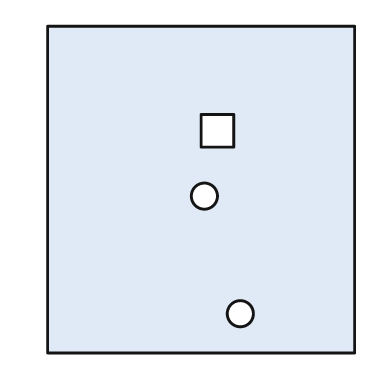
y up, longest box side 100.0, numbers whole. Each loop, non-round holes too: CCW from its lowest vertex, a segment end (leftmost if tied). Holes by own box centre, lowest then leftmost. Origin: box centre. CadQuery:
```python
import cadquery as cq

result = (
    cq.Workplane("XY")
    .moveTo(-47.0, -50.0)
    .lineTo(47.0, -50.0)
    .lineTo(47.0, 50.0)
    .lineTo(-47.0, 50.0)
    .close()
    .moveTo(12.0, -38.0)
    .circle(4.0)
    .moveTo(1.0, -2.0)
    .circle(4.0)
    .moveTo(0.0, 13.0)
    .lineTo(10.0, 13.0)
    .lineTo(10.0, 23.0)
    .lineTo(0.0, 23.0)
    .close()
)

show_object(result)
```